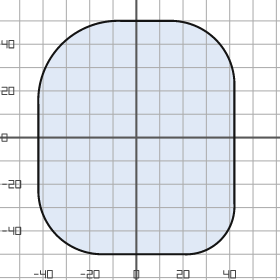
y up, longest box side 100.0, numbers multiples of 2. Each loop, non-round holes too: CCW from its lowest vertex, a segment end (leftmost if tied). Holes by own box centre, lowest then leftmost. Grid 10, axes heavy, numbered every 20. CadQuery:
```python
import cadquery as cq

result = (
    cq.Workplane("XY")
    .moveTo(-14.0, -50.0)
    .lineTo(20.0, -50.0)
    .threePointArc((36.0, -44.0), (42.0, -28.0))
    .lineTo(42.0, 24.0)
    .threePointArc((34.0, 42.0), (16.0, 50.0))
    .lineTo(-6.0, 50.0)
    .threePointArc((-32.0, 40.0), (-42.0, 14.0))
    .lineTo(-42.0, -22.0)
    .threePointArc((-34.0, -42.0), (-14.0, -50.0))
    .close()
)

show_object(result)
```